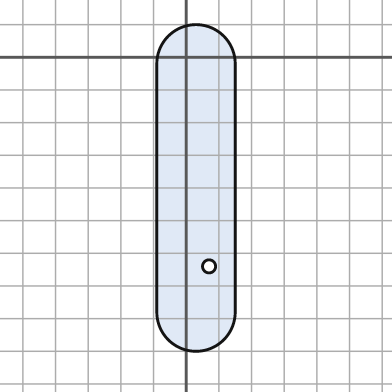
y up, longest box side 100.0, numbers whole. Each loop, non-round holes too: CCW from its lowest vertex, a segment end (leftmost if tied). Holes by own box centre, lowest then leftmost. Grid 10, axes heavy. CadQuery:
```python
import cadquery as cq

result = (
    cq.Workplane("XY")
    .moveTo(-9.0, -78.0)
    .threePointArc((3.0, -90.0), (15.0, -78.0))
    .lineTo(15.0, -2.0)
    .threePointArc((3.0, 10.0), (-9.0, -2.0))
    .close()
    .moveTo(7.0, -64.0)
    .circle(2.0)
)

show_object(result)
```